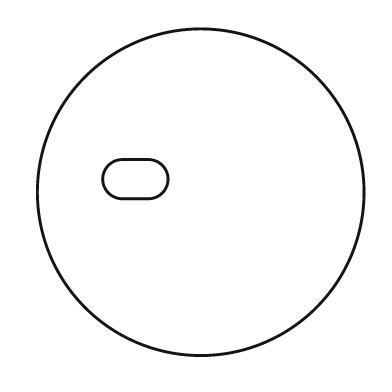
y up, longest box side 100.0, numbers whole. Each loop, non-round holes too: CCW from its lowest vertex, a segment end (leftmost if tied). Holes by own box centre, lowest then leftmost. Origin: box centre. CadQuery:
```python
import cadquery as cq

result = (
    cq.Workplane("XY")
    .moveTo(0.0, 0.0)
    .circle(50.0)
    .moveTo(-24.0, -2.0)
    .lineTo(-16.0, -2.0)
    .threePointArc((-10.0, 4.0), (-16.0, 10.0))
    .lineTo(-24.0, 10.0)
    .threePointArc((-30.0, 4.0), (-24.0, -2.0))
    .close()
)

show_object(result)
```